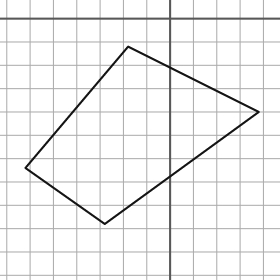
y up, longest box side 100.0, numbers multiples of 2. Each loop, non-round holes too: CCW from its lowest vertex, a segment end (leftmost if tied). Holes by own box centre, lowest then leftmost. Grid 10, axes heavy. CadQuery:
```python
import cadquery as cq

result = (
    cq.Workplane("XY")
    .moveTo(-28.0, -88.0)
    .lineTo(38.0, -40.0)
    .lineTo(-18.0, -12.0)
    .lineTo(-62.0, -64.0)
    .close()
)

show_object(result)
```